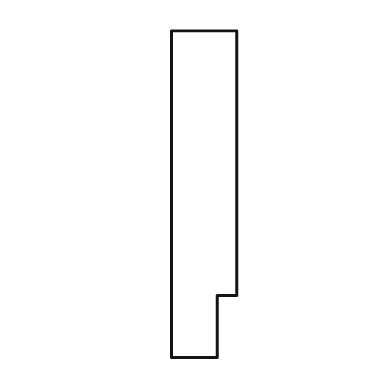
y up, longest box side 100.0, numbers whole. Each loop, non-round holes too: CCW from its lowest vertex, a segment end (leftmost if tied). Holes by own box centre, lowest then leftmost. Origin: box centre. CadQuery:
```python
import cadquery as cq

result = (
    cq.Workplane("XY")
    .moveTo(-10.0, -50.0)
    .lineTo(4.0, -50.0)
    .lineTo(4.0, -31.0)
    .lineTo(10.0, -31.0)
    .lineTo(10.0, 50.0)
    .lineTo(-10.0, 50.0)
    .close()
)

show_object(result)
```